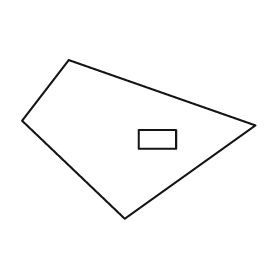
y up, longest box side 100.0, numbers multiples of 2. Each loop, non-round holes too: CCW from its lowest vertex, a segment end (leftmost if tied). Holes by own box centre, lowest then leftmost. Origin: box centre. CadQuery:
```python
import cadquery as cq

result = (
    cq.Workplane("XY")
    .moveTo(-6.0, -34.0)
    .lineTo(50.0, 6.0)
    .lineTo(-30.0, 34.0)
    .lineTo(-50.0, 8.0)
    .close()
    .moveTo(0.0, -4.0)
    .lineTo(16.0, -4.0)
    .lineTo(16.0, 4.0)
    .lineTo(0.0, 4.0)
    .close()
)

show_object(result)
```